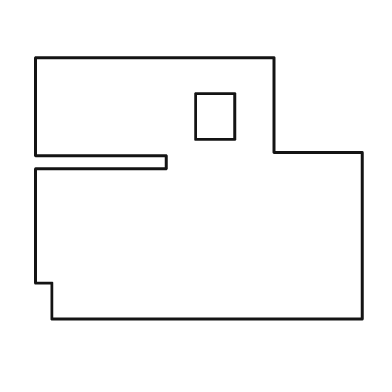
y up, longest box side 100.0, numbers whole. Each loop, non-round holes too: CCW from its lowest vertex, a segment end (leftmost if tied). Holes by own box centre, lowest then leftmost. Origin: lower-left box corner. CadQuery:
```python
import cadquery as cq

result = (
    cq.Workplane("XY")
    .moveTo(5.0, 0.0)
    .lineTo(100.0, 0.0)
    .lineTo(100.0, 51.0)
    .lineTo(73.0, 51.0)
    .lineTo(73.0, 80.0)
    .lineTo(0.0, 80.0)
    .lineTo(0.0, 50.0)
    .lineTo(40.0, 50.0)
    .lineTo(40.0, 46.0)
    .lineTo(0.0, 46.0)
    .lineTo(0.0, 11.0)
    .lineTo(5.0, 11.0)
    .close()
    .moveTo(49.0, 55.0)
    .lineTo(61.0, 55.0)
    .lineTo(61.0, 69.0)
    .lineTo(49.0, 69.0)
    .close()
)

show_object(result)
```